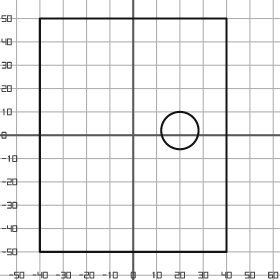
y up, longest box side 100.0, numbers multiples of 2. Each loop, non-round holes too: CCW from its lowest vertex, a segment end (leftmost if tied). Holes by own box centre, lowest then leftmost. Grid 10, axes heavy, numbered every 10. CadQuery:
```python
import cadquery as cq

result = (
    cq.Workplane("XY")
    .moveTo(-40.0, -50.0)
    .lineTo(40.0, -50.0)
    .lineTo(40.0, 50.0)
    .lineTo(-40.0, 50.0)
    .close()
    .moveTo(20.0, 2.0)
    .circle(8.0)
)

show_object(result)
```